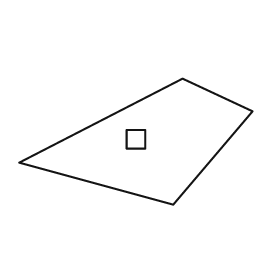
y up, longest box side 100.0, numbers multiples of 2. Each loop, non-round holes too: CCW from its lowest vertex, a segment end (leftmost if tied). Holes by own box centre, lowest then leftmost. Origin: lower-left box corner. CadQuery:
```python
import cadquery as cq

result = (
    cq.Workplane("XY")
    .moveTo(66.0, 0.0)
    .lineTo(100.0, 40.0)
    .lineTo(70.0, 54.0)
    .lineTo(0.0, 18.0)
    .close()
    .moveTo(46.0, 24.0)
    .lineTo(54.0, 24.0)
    .lineTo(54.0, 32.0)
    .lineTo(46.0, 32.0)
    .close()
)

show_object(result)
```